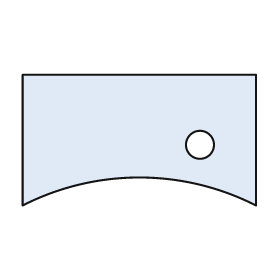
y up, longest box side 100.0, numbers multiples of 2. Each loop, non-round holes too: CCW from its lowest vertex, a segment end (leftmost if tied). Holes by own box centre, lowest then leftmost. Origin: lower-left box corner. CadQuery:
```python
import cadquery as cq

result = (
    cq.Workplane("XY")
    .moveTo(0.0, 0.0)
    .threePointArc((50.0, 12.0), (100.0, 0.0))
    .lineTo(100.0, 56.0)
    .lineTo(0.0, 56.0)
    .close()
    .moveTo(76.0, 26.0)
    .circle(6.0)
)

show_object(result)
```